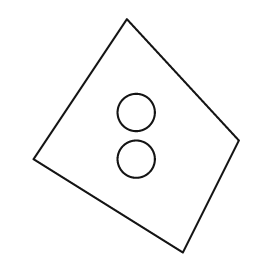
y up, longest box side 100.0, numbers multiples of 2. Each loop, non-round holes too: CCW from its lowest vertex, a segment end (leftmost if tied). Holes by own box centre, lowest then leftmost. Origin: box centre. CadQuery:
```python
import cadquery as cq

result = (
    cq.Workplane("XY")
    .moveTo(20.0, -50.0)
    .lineTo(44.0, -2.0)
    .lineTo(-4.0, 50.0)
    .lineTo(-44.0, -10.0)
    .close()
    .moveTo(0.0, -10.0)
    .circle(8.0)
    .moveTo(0.0, 10.0)
    .circle(8.0)
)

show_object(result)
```